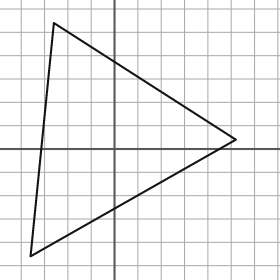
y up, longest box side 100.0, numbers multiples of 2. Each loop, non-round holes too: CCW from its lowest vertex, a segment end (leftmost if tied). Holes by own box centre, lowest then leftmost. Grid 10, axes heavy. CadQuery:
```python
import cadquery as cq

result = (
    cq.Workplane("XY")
    .moveTo(-36.0, -46.0)
    .lineTo(52.0, 4.0)
    .lineTo(-26.0, 54.0)
    .close()
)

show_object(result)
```